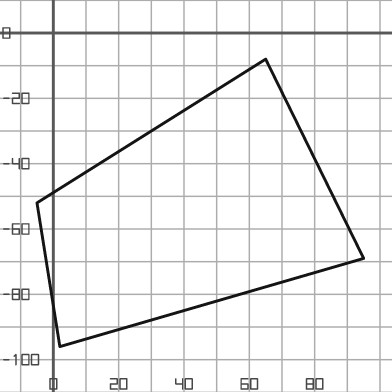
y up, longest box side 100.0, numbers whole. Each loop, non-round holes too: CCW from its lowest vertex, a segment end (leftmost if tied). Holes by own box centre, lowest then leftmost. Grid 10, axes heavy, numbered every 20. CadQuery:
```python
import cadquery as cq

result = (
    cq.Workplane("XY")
    .moveTo(2.0, -96.0)
    .lineTo(95.0, -69.0)
    .lineTo(65.0, -8.0)
    .lineTo(-5.0, -52.0)
    .close()
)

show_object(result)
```